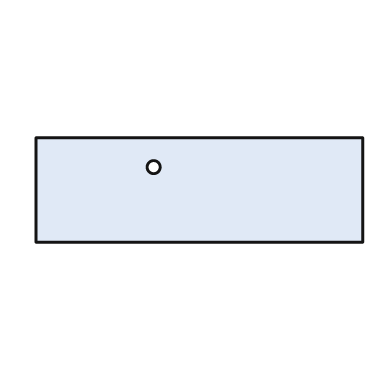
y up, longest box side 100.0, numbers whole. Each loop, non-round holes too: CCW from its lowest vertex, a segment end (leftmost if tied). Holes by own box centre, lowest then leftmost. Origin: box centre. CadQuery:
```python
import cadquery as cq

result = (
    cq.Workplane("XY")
    .moveTo(-50.0, -16.0)
    .lineTo(50.0, -16.0)
    .lineTo(50.0, 16.0)
    .lineTo(-50.0, 16.0)
    .close()
    .moveTo(-14.0, 7.0)
    .circle(2.0)
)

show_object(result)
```